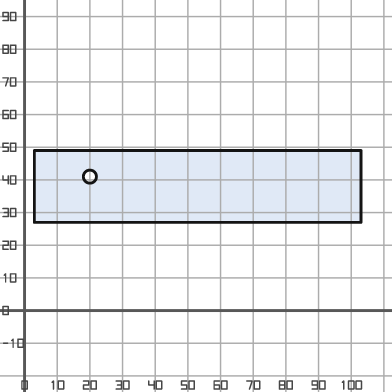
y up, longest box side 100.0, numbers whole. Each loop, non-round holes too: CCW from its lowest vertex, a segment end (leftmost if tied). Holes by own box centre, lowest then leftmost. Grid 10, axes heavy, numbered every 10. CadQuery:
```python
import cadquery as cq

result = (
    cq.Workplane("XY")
    .moveTo(3.0, 27.0)
    .lineTo(103.0, 27.0)
    .lineTo(103.0, 49.0)
    .lineTo(3.0, 49.0)
    .close()
    .moveTo(20.0, 41.0)
    .circle(2.0)
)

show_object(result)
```